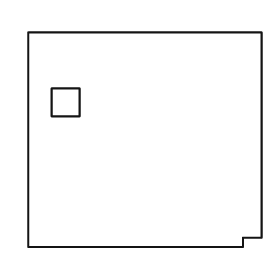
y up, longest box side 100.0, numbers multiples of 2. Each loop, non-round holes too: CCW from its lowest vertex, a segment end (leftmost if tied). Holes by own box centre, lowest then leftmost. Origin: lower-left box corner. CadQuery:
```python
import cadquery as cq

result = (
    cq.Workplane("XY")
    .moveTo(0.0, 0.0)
    .lineTo(92.0, 0.0)
    .lineTo(92.0, 4.0)
    .lineTo(100.0, 4.0)
    .lineTo(100.0, 92.0)
    .lineTo(0.0, 92.0)
    .close()
    .moveTo(10.0, 56.0)
    .lineTo(22.0, 56.0)
    .lineTo(22.0, 68.0)
    .lineTo(10.0, 68.0)
    .close()
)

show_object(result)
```